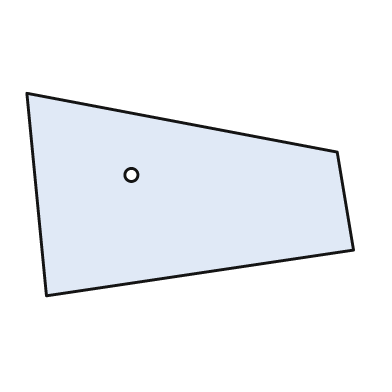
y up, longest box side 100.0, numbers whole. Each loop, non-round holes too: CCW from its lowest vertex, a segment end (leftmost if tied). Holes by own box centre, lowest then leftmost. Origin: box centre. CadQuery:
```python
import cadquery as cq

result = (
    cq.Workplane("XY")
    .moveTo(-44.0, -31.0)
    .lineTo(50.0, -17.0)
    .lineTo(45.0, 13.0)
    .lineTo(-50.0, 31.0)
    .close()
    .moveTo(-18.0, 6.0)
    .circle(2.0)
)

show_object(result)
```